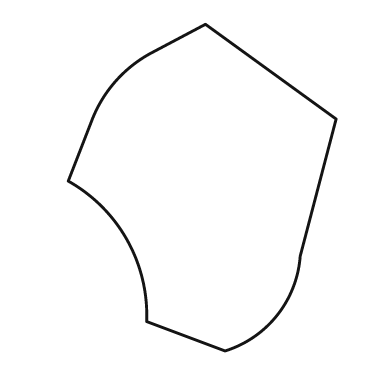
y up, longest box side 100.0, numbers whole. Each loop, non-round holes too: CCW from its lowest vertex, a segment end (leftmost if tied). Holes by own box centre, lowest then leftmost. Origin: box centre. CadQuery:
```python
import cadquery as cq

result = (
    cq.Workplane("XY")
    .moveTo(7.0, -50.0)
    .threePointArc((23.0, -39.0), (30.0, -21.0))
    .lineTo(41.0, 21.0)
    .lineTo(1.0, 50.0)
    .lineTo(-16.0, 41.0)
    .threePointArc((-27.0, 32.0), (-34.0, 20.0))
    .lineTo(-41.0, 2.0)
    .threePointArc((-23.0, -16.0), (-17.0, -41.0))
    .close()
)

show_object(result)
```